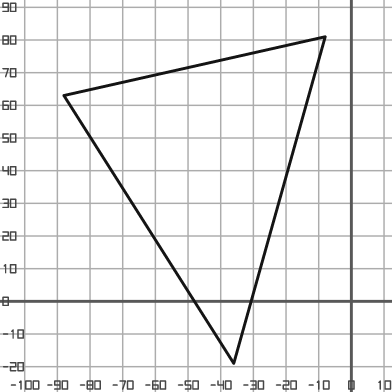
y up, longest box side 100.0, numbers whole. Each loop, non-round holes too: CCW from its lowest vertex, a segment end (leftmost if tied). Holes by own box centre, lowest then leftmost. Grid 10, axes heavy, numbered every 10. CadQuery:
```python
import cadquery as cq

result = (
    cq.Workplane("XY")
    .moveTo(-36.0, -19.0)
    .lineTo(-8.0, 81.0)
    .lineTo(-88.0, 63.0)
    .close()
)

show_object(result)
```